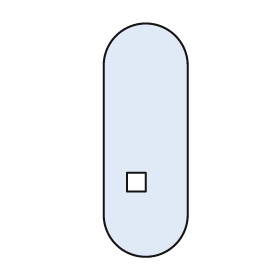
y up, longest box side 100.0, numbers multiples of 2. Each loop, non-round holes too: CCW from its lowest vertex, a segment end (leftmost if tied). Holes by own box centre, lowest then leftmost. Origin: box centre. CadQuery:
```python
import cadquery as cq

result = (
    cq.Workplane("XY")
    .moveTo(-18.0, -32.0)
    .threePointArc((0.0, -50.0), (18.0, -32.0))
    .lineTo(18.0, 32.0)
    .threePointArc((0.0, 50.0), (-18.0, 32.0))
    .close()
    .moveTo(-8.0, -22.0)
    .lineTo(0.0, -22.0)
    .lineTo(0.0, -14.0)
    .lineTo(-8.0, -14.0)
    .close()
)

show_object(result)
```